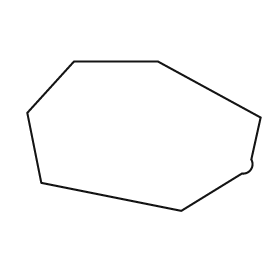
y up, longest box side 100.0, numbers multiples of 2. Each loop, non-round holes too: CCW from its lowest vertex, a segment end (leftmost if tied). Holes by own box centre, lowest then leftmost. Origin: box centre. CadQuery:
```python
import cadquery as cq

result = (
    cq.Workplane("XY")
    .moveTo(16.0, -32.0)
    .lineTo(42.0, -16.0)
    .threePointArc((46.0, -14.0), (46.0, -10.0))
    .lineTo(50.0, 8.0)
    .lineTo(6.0, 32.0)
    .lineTo(-30.0, 32.0)
    .lineTo(-50.0, 10.0)
    .lineTo(-44.0, -20.0)
    .close()
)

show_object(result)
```